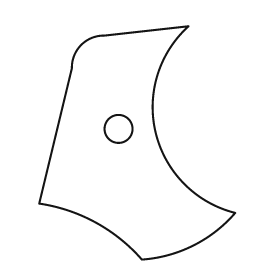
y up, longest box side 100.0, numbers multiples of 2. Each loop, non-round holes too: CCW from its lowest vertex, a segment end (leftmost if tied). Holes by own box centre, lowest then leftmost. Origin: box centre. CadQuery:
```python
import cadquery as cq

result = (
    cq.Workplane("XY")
    .moveTo(2.0, -50.0)
    .threePointArc((24.0, -44.0), (42.0, -30.0))
    .threePointArc((8.0, 4.0), (22.0, 50.0))
    .lineTo(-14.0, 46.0)
    .threePointArc((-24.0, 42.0), (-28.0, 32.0))
    .lineTo(-42.0, -26.0)
    .threePointArc((-18.0, -34.0), (2.0, -50.0))
    .close()
    .moveTo(-8.0, 6.0)
    .circle(6.0)
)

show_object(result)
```